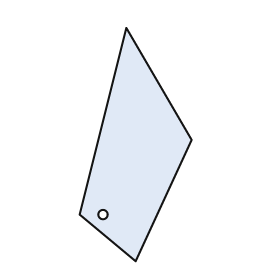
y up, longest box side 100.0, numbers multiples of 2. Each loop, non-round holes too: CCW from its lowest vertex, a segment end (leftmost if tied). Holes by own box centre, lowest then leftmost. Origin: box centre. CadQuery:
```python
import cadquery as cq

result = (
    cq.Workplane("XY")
    .moveTo(0.0, -50.0)
    .lineTo(24.0, 2.0)
    .lineTo(-4.0, 50.0)
    .lineTo(-24.0, -30.0)
    .close()
    .moveTo(-14.0, -30.0)
    .circle(2.0)
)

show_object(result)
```